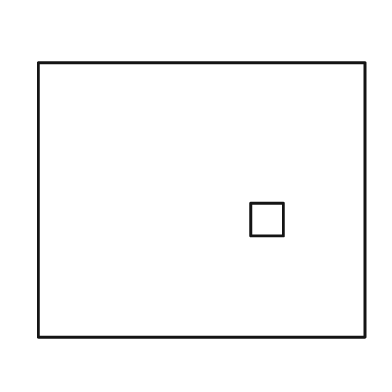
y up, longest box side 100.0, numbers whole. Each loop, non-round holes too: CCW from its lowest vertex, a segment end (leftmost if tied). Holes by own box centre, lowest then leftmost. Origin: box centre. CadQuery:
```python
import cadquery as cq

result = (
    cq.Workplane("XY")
    .moveTo(-50.0, -42.0)
    .lineTo(50.0, -42.0)
    .lineTo(50.0, 42.0)
    .lineTo(-50.0, 42.0)
    .close()
    .moveTo(15.0, -11.0)
    .lineTo(25.0, -11.0)
    .lineTo(25.0, -1.0)
    .lineTo(15.0, -1.0)
    .close()
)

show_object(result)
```